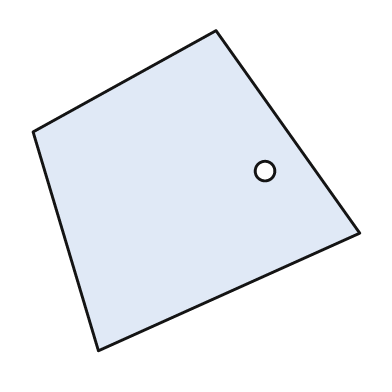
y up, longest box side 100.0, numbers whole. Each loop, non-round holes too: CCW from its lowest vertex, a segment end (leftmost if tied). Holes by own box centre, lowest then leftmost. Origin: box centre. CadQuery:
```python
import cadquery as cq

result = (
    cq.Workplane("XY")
    .moveTo(-30.0, -49.0)
    .lineTo(50.0, -13.0)
    .lineTo(6.0, 49.0)
    .lineTo(-50.0, 18.0)
    .close()
    .moveTo(21.0, 6.0)
    .circle(3.0)
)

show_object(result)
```